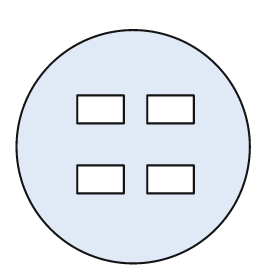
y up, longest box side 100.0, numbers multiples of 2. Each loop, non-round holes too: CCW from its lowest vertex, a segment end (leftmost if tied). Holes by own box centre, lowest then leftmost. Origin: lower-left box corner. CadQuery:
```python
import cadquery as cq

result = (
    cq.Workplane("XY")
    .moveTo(50.0, 50.0)
    .circle(50.0)
    .moveTo(26.0, 30.0)
    .lineTo(46.0, 30.0)
    .lineTo(46.0, 42.0)
    .lineTo(26.0, 42.0)
    .close()
    .moveTo(56.0, 30.0)
    .lineTo(76.0, 30.0)
    .lineTo(76.0, 42.0)
    .lineTo(56.0, 42.0)
    .close()
    .moveTo(26.0, 60.0)
    .lineTo(46.0, 60.0)
    .lineTo(46.0, 72.0)
    .lineTo(26.0, 72.0)
    .close()
    .moveTo(56.0, 60.0)
    .lineTo(76.0, 60.0)
    .lineTo(76.0, 72.0)
    .lineTo(56.0, 72.0)
    .close()
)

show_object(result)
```